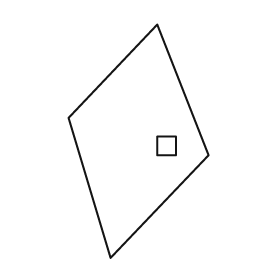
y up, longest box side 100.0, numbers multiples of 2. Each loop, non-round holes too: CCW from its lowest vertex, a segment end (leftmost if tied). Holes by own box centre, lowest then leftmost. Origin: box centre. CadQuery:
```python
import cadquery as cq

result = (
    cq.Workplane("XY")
    .moveTo(-12.0, -50.0)
    .lineTo(30.0, -6.0)
    .lineTo(8.0, 50.0)
    .lineTo(-30.0, 10.0)
    .close()
    .moveTo(8.0, -6.0)
    .lineTo(16.0, -6.0)
    .lineTo(16.0, 2.0)
    .lineTo(8.0, 2.0)
    .close()
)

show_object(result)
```